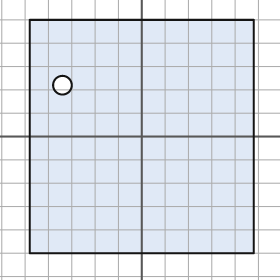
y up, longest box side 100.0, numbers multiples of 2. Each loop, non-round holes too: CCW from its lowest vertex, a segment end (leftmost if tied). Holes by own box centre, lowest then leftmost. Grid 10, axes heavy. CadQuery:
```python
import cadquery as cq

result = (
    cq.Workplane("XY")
    .moveTo(-48.0, -50.0)
    .lineTo(48.0, -50.0)
    .lineTo(48.0, 50.0)
    .lineTo(-48.0, 50.0)
    .close()
    .moveTo(-34.0, 22.0)
    .circle(4.0)
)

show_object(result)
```